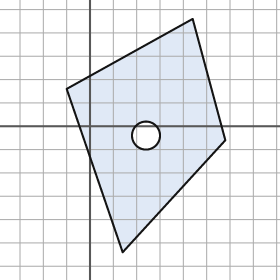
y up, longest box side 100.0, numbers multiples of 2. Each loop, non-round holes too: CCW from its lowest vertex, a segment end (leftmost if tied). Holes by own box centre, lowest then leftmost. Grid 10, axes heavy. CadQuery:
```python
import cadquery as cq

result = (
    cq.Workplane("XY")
    .moveTo(14.0, -54.0)
    .lineTo(58.0, -6.0)
    .lineTo(44.0, 46.0)
    .lineTo(-10.0, 16.0)
    .close()
    .moveTo(24.0, -4.0)
    .circle(6.0)
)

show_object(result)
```